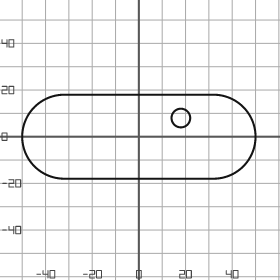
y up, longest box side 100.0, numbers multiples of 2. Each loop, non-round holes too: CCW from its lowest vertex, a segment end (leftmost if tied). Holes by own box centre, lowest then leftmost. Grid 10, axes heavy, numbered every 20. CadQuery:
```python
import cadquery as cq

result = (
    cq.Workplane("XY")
    .moveTo(-32.0, -18.0)
    .lineTo(32.0, -18.0)
    .threePointArc((50.0, 0.0), (32.0, 18.0))
    .lineTo(-32.0, 18.0)
    .threePointArc((-50.0, 0.0), (-32.0, -18.0))
    .close()
    .moveTo(18.0, 8.0)
    .circle(4.0)
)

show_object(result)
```